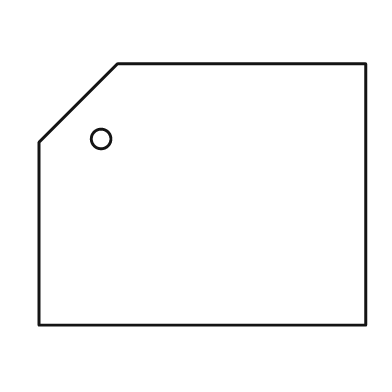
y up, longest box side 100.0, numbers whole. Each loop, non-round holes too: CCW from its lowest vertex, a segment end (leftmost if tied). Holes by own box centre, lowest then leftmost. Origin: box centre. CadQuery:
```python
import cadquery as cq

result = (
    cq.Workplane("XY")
    .moveTo(-50.0, -40.0)
    .lineTo(50.0, -40.0)
    .lineTo(50.0, 40.0)
    .lineTo(-26.0, 40.0)
    .lineTo(-50.0, 16.0)
    .close()
    .moveTo(-31.0, 17.0)
    .circle(3.0)
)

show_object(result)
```